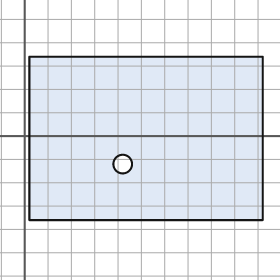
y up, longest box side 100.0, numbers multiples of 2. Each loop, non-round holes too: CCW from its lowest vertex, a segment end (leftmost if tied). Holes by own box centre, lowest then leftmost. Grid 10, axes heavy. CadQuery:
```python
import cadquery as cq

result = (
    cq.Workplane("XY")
    .moveTo(2.0, -36.0)
    .lineTo(102.0, -36.0)
    .lineTo(102.0, 34.0)
    .lineTo(2.0, 34.0)
    .close()
    .moveTo(42.0, -12.0)
    .circle(4.0)
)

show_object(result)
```